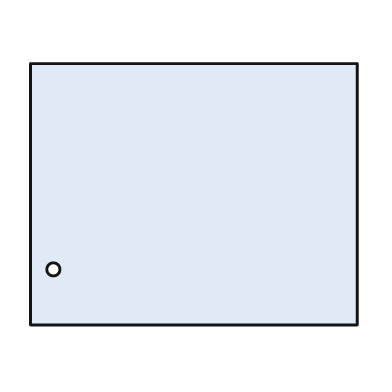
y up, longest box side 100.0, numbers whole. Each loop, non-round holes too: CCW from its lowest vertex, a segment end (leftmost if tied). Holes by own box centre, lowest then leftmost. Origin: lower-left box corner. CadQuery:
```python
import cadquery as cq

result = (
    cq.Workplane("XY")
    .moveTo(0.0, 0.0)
    .lineTo(100.0, 0.0)
    .lineTo(100.0, 80.0)
    .lineTo(0.0, 80.0)
    .close()
    .moveTo(7.0, 17.0)
    .circle(2.0)
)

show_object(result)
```